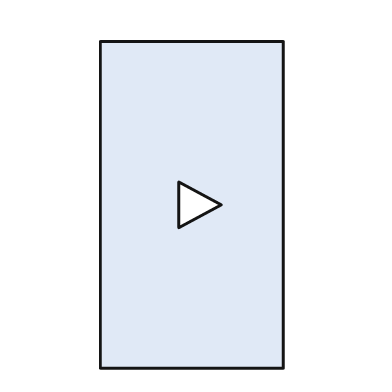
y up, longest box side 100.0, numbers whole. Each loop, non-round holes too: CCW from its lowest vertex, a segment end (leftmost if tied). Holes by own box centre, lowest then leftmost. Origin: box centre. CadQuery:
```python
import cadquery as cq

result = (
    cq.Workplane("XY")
    .moveTo(-28.0, -50.0)
    .lineTo(28.0, -50.0)
    .lineTo(28.0, 50.0)
    .lineTo(-28.0, 50.0)
    .close()
    .moveTo(-4.0, -7.0)
    .lineTo(9.0, 0.0)
    .lineTo(-4.0, 7.0)
    .close()
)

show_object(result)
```